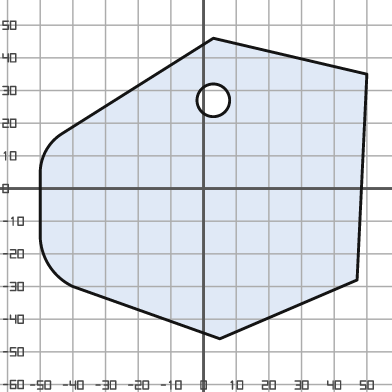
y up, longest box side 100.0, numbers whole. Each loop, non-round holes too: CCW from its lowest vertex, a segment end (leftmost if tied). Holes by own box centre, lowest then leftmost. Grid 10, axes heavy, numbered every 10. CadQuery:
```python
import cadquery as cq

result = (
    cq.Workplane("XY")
    .moveTo(5.0, -46.0)
    .lineTo(47.0, -28.0)
    .lineTo(50.0, 35.0)
    .lineTo(3.0, 46.0)
    .lineTo(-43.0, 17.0)
    .threePointArc((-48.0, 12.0), (-50.0, 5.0))
    .lineTo(-50.0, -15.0)
    .threePointArc((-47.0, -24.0), (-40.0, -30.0))
    .close()
    .moveTo(3.0, 27.0)
    .circle(5.0)
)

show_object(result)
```